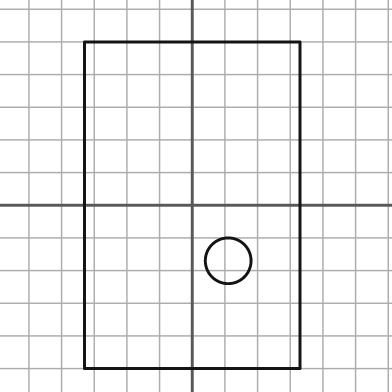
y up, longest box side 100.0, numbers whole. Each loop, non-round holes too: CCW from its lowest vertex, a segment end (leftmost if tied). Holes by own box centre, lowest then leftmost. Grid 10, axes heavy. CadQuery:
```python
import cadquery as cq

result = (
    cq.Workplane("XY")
    .moveTo(-33.0, -50.0)
    .lineTo(33.0, -50.0)
    .lineTo(33.0, 50.0)
    .lineTo(-33.0, 50.0)
    .close()
    .moveTo(11.0, -17.0)
    .circle(7.0)
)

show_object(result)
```